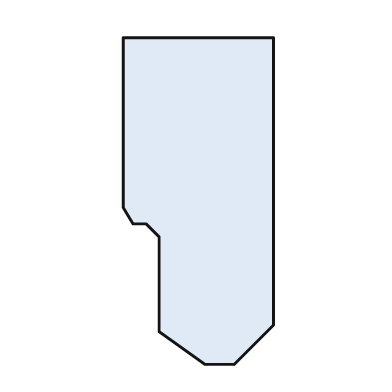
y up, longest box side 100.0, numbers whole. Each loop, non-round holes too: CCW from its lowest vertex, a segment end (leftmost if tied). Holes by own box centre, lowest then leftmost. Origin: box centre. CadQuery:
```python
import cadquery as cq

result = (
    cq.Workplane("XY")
    .moveTo(2.0, -50.0)
    .lineTo(11.0, -50.0)
    .lineTo(23.0, -38.0)
    .lineTo(23.0, 50.0)
    .lineTo(-23.0, 50.0)
    .lineTo(-23.0, -2.0)
    .lineTo(-20.0, -7.0)
    .lineTo(-16.0, -7.0)
    .lineTo(-12.0, -11.0)
    .lineTo(-12.0, -40.0)
    .close()
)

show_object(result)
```